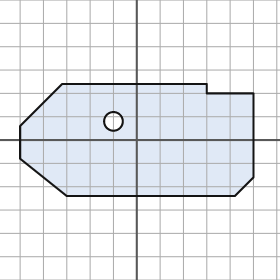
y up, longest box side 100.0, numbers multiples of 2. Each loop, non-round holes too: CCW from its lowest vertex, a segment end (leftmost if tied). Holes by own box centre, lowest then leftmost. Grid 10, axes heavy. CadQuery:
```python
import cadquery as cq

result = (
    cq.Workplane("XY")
    .moveTo(-30.0, -24.0)
    .lineTo(42.0, -24.0)
    .lineTo(50.0, -16.0)
    .lineTo(50.0, 20.0)
    .lineTo(30.0, 20.0)
    .lineTo(30.0, 24.0)
    .lineTo(-32.0, 24.0)
    .lineTo(-50.0, 6.0)
    .lineTo(-50.0, -8.0)
    .close()
    .moveTo(-10.0, 8.0)
    .circle(4.0)
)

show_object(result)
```